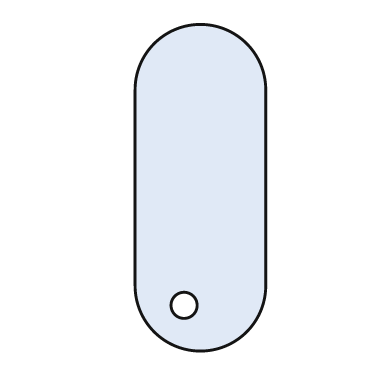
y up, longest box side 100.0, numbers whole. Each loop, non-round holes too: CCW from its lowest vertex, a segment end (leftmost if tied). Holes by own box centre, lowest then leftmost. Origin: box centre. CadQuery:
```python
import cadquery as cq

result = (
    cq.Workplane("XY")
    .moveTo(-20.0, -30.0)
    .threePointArc((0.0, -50.0), (20.0, -30.0))
    .lineTo(20.0, 30.0)
    .threePointArc((0.0, 50.0), (-20.0, 30.0))
    .close()
    .moveTo(-5.0, -36.0)
    .circle(4.0)
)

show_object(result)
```